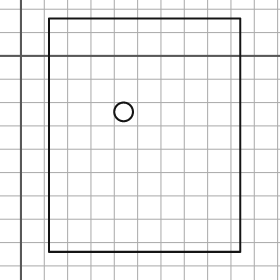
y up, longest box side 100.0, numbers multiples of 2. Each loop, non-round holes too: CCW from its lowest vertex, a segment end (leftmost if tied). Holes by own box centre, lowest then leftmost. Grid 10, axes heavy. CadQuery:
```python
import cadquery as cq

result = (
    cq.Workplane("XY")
    .moveTo(12.0, -84.0)
    .lineTo(94.0, -84.0)
    .lineTo(94.0, 16.0)
    .lineTo(12.0, 16.0)
    .close()
    .moveTo(44.0, -24.0)
    .circle(4.0)
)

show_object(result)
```